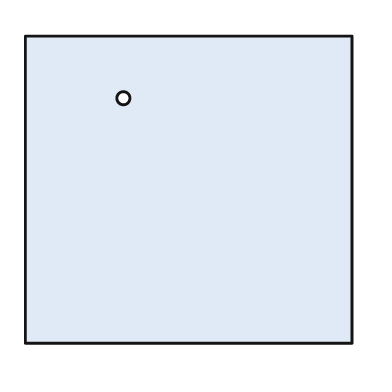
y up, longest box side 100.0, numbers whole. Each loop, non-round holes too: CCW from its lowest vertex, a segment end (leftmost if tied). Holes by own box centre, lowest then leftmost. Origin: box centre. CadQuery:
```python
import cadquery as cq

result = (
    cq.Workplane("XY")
    .moveTo(-50.0, -47.0)
    .lineTo(50.0, -47.0)
    .lineTo(50.0, 47.0)
    .lineTo(-50.0, 47.0)
    .close()
    .moveTo(-20.0, 28.0)
    .circle(2.0)
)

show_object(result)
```